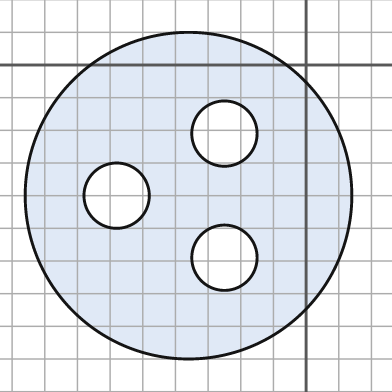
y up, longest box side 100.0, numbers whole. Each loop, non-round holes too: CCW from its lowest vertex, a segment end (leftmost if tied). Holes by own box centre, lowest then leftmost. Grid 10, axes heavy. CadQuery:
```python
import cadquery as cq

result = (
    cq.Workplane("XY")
    .moveTo(-36.0, -40.0)
    .circle(50.0)
    .moveTo(-25.0, -59.0)
    .circle(10.0)
    .moveTo(-58.0, -40.0)
    .circle(10.0)
    .moveTo(-25.0, -21.0)
    .circle(10.0)
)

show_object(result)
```